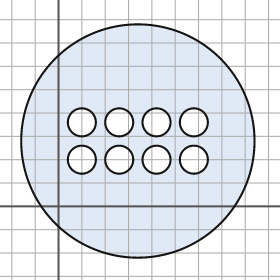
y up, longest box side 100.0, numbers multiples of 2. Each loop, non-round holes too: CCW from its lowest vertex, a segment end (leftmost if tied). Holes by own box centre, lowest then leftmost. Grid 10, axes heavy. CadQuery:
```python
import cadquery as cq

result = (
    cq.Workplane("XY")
    .moveTo(34.0, 28.0)
    .circle(50.0)
    .moveTo(10.0, 20.0)
    .circle(6.0)
    .moveTo(26.0, 20.0)
    .circle(6.0)
    .moveTo(42.0, 20.0)
    .circle(6.0)
    .moveTo(58.0, 20.0)
    .circle(6.0)
    .moveTo(10.0, 36.0)
    .circle(6.0)
    .moveTo(26.0, 36.0)
    .circle(6.0)
    .moveTo(42.0, 36.0)
    .circle(6.0)
    .moveTo(58.0, 36.0)
    .circle(6.0)
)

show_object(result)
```